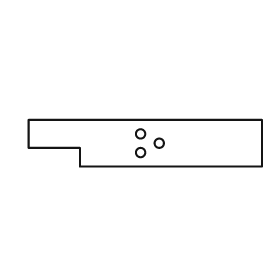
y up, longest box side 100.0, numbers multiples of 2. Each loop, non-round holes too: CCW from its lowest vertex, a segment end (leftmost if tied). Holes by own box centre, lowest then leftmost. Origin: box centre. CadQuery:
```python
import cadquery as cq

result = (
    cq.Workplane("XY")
    .moveTo(-28.0, -10.0)
    .lineTo(50.0, -10.0)
    .lineTo(50.0, 10.0)
    .lineTo(-50.0, 10.0)
    .lineTo(-50.0, -2.0)
    .lineTo(-28.0, -2.0)
    .close()
    .moveTo(-2.0, -4.0)
    .circle(2.0)
    .moveTo(6.0, 0.0)
    .circle(2.0)
    .moveTo(-2.0, 4.0)
    .circle(2.0)
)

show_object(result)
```